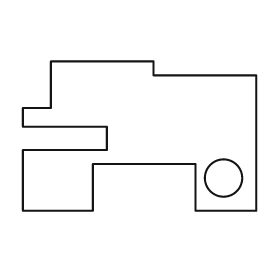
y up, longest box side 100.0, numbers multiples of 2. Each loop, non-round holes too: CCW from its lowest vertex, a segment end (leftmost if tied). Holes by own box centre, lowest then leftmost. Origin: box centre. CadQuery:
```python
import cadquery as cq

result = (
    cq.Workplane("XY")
    .moveTo(-50.0, -32.0)
    .lineTo(-20.0, -32.0)
    .lineTo(-20.0, -12.0)
    .lineTo(24.0, -12.0)
    .lineTo(24.0, -32.0)
    .lineTo(50.0, -32.0)
    .lineTo(50.0, 26.0)
    .lineTo(6.0, 26.0)
    .lineTo(6.0, 32.0)
    .lineTo(-38.0, 32.0)
    .lineTo(-38.0, 12.0)
    .lineTo(-50.0, 12.0)
    .lineTo(-50.0, 4.0)
    .lineTo(-14.0, 4.0)
    .lineTo(-14.0, -6.0)
    .lineTo(-50.0, -6.0)
    .close()
    .moveTo(36.0, -18.0)
    .circle(8.0)
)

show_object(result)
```